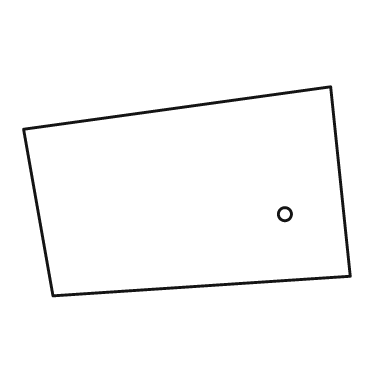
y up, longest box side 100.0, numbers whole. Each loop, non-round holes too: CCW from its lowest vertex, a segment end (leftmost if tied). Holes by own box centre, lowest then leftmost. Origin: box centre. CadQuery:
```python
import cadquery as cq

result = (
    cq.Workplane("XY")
    .moveTo(-41.0, -32.0)
    .lineTo(50.0, -26.0)
    .lineTo(44.0, 32.0)
    .lineTo(-50.0, 19.0)
    .close()
    .moveTo(30.0, -7.0)
    .circle(2.0)
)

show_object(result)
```